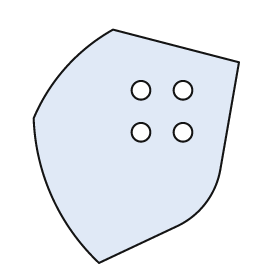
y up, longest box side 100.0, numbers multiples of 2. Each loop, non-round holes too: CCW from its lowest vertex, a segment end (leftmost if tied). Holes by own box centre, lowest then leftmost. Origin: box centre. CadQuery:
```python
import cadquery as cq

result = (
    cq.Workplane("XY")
    .moveTo(-16.0, -50.0)
    .lineTo(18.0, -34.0)
    .threePointArc((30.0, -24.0), (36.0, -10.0))
    .lineTo(44.0, 36.0)
    .lineTo(-10.0, 50.0)
    .threePointArc((-30.0, 34.0), (-44.0, 12.0))
    .threePointArc((-36.0, -22.0), (-16.0, -50.0))
    .close()
    .moveTo(2.0, 6.0)
    .circle(4.0)
    .moveTo(20.0, 6.0)
    .circle(4.0)
    .moveTo(2.0, 24.0)
    .circle(4.0)
    .moveTo(20.0, 24.0)
    .circle(4.0)
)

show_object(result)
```